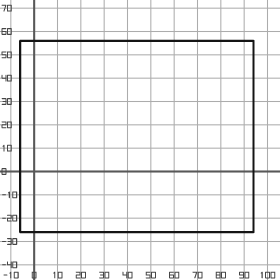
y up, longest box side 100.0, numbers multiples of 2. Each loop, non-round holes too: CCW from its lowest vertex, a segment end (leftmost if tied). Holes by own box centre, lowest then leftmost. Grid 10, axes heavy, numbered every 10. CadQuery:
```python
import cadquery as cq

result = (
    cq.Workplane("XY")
    .moveTo(-6.0, -26.0)
    .lineTo(94.0, -26.0)
    .lineTo(94.0, 56.0)
    .lineTo(-6.0, 56.0)
    .close()
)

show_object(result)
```